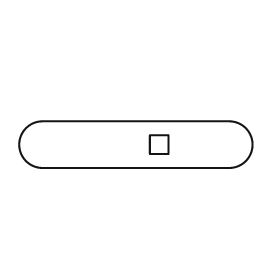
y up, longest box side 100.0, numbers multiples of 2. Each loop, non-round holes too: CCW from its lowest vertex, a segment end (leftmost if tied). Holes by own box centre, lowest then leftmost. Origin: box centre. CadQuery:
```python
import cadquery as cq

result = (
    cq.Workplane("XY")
    .moveTo(-40.0, -10.0)
    .lineTo(40.0, -10.0)
    .threePointArc((50.0, 0.0), (40.0, 10.0))
    .lineTo(-40.0, 10.0)
    .threePointArc((-50.0, 0.0), (-40.0, -10.0))
    .close()
    .moveTo(6.0, -4.0)
    .lineTo(14.0, -4.0)
    .lineTo(14.0, 4.0)
    .lineTo(6.0, 4.0)
    .close()
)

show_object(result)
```